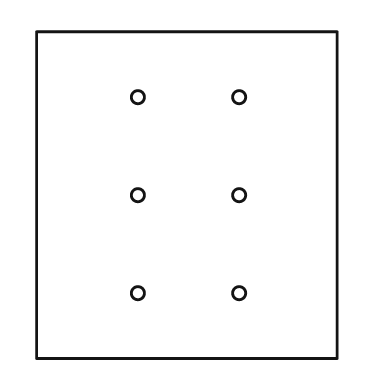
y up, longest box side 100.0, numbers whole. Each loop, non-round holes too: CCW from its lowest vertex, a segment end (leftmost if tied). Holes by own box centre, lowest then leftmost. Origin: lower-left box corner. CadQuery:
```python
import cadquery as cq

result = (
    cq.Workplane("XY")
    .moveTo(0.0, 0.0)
    .lineTo(92.0, 0.0)
    .lineTo(92.0, 100.0)
    .lineTo(0.0, 100.0)
    .close()
    .moveTo(31.0, 20.0)
    .circle(2.0)
    .moveTo(62.0, 20.0)
    .circle(2.0)
    .moveTo(31.0, 50.0)
    .circle(2.0)
    .moveTo(62.0, 50.0)
    .circle(2.0)
    .moveTo(31.0, 80.0)
    .circle(2.0)
    .moveTo(62.0, 80.0)
    .circle(2.0)
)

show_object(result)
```